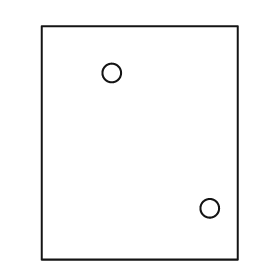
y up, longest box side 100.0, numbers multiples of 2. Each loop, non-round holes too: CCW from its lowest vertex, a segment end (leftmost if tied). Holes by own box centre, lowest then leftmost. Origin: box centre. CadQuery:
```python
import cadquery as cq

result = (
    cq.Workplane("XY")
    .moveTo(-42.0, -50.0)
    .lineTo(42.0, -50.0)
    .lineTo(42.0, 50.0)
    .lineTo(-42.0, 50.0)
    .close()
    .moveTo(30.0, -28.0)
    .circle(4.0)
    .moveTo(-12.0, 30.0)
    .circle(4.0)
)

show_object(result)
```